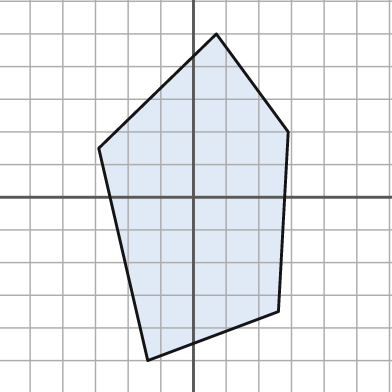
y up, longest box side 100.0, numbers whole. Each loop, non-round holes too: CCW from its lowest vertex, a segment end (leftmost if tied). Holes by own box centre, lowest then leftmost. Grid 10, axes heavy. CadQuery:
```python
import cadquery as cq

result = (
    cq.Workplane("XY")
    .moveTo(-14.0, -50.0)
    .lineTo(26.0, -35.0)
    .lineTo(29.0, 20.0)
    .lineTo(7.0, 50.0)
    .lineTo(-29.0, 15.0)
    .close()
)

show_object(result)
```